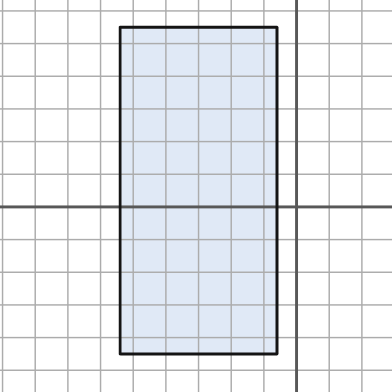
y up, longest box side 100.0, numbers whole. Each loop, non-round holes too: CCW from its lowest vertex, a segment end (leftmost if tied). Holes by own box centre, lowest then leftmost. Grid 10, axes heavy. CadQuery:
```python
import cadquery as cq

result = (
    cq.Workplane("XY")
    .moveTo(-54.0, -45.0)
    .lineTo(-6.0, -45.0)
    .lineTo(-6.0, 55.0)
    .lineTo(-54.0, 55.0)
    .close()
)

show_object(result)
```